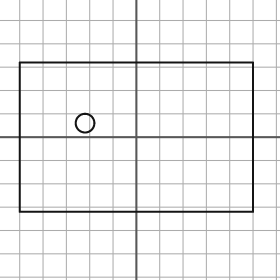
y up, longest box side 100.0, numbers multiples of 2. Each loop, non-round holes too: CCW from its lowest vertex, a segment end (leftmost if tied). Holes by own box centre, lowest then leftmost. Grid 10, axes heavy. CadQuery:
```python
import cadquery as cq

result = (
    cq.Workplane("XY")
    .moveTo(-50.0, -32.0)
    .lineTo(50.0, -32.0)
    .lineTo(50.0, 32.0)
    .lineTo(-50.0, 32.0)
    .close()
    .moveTo(-22.0, 6.0)
    .circle(4.0)
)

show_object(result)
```